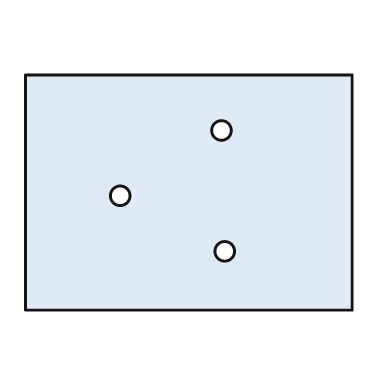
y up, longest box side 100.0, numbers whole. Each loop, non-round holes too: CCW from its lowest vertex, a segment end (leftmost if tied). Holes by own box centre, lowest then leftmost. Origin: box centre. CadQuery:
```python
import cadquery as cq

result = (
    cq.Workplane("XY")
    .moveTo(-50.0, -36.0)
    .lineTo(50.0, -36.0)
    .lineTo(50.0, 36.0)
    .lineTo(-50.0, 36.0)
    .close()
    .moveTo(11.0, -18.0)
    .circle(3.0)
    .moveTo(-21.0, -1.0)
    .circle(3.0)
    .moveTo(10.0, 19.0)
    .circle(3.0)
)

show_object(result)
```